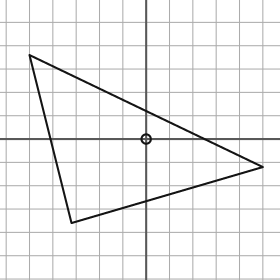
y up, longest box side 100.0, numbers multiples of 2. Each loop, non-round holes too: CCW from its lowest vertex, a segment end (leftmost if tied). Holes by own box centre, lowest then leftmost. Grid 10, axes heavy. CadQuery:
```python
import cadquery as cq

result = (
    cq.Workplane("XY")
    .moveTo(-32.0, -36.0)
    .lineTo(50.0, -12.0)
    .lineTo(-50.0, 36.0)
    .close()
    .moveTo(0.0, 0.0)
    .circle(2.0)
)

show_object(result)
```